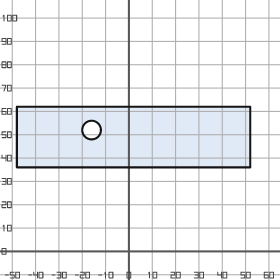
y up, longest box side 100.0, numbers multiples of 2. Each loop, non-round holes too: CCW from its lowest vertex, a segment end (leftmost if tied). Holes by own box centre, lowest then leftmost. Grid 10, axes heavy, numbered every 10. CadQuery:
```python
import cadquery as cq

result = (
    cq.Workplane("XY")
    .moveTo(-48.0, 36.0)
    .lineTo(52.0, 36.0)
    .lineTo(52.0, 62.0)
    .lineTo(-48.0, 62.0)
    .close()
    .moveTo(-16.0, 52.0)
    .circle(4.0)
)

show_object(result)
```